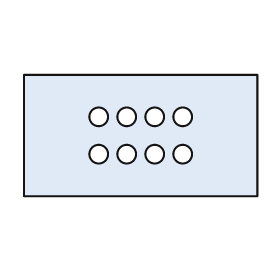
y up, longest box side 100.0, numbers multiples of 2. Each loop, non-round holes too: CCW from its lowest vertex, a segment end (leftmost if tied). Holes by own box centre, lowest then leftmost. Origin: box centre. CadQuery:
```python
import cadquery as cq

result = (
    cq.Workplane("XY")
    .moveTo(-50.0, -26.0)
    .lineTo(50.0, -26.0)
    .lineTo(50.0, 26.0)
    .lineTo(-50.0, 26.0)
    .close()
    .moveTo(-18.0, -8.0)
    .circle(4.0)
    .moveTo(-6.0, -8.0)
    .circle(4.0)
    .moveTo(6.0, -8.0)
    .circle(4.0)
    .moveTo(18.0, -8.0)
    .circle(4.0)
    .moveTo(-18.0, 8.0)
    .circle(4.0)
    .moveTo(-6.0, 8.0)
    .circle(4.0)
    .moveTo(6.0, 8.0)
    .circle(4.0)
    .moveTo(18.0, 8.0)
    .circle(4.0)
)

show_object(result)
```